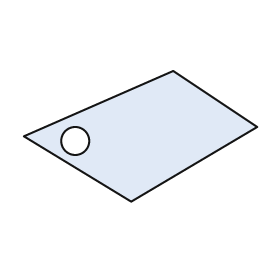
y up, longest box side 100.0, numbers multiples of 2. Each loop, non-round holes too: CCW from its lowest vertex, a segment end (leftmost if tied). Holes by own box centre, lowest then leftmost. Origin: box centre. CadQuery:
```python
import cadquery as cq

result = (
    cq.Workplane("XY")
    .moveTo(-4.0, -28.0)
    .lineTo(50.0, 4.0)
    .lineTo(14.0, 28.0)
    .lineTo(-50.0, 0.0)
    .close()
    .moveTo(-28.0, -2.0)
    .circle(6.0)
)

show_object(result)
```